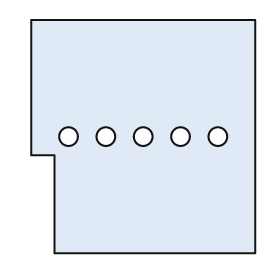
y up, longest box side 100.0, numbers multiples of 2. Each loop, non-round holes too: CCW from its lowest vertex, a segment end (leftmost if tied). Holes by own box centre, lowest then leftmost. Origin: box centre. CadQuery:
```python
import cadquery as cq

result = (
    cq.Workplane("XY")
    .moveTo(-38.0, -50.0)
    .lineTo(48.0, -50.0)
    .lineTo(48.0, 50.0)
    .lineTo(-48.0, 50.0)
    .lineTo(-48.0, -8.0)
    .lineTo(-38.0, -8.0)
    .close()
    .moveTo(-32.0, 0.0)
    .circle(4.0)
    .moveTo(-16.0, 0.0)
    .circle(4.0)
    .moveTo(0.0, 0.0)
    .circle(4.0)
    .moveTo(16.0, 0.0)
    .circle(4.0)
    .moveTo(32.0, 0.0)
    .circle(4.0)
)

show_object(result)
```